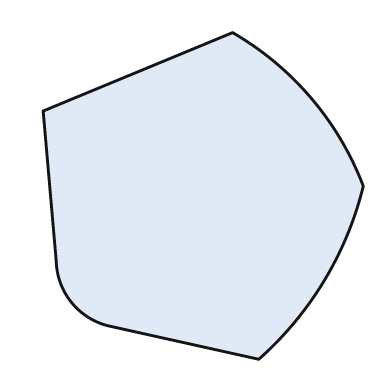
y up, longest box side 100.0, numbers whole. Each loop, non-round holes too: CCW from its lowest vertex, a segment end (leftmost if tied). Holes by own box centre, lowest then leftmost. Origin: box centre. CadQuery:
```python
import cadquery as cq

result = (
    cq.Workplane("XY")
    .moveTo(17.0, -50.0)
    .threePointArc((37.0, -26.0), (49.0, 3.0))
    .threePointArc((33.0, 30.0), (9.0, 50.0))
    .lineTo(-49.0, 26.0)
    .lineTo(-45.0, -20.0)
    .threePointArc((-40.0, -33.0), (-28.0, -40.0))
    .close()
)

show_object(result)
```